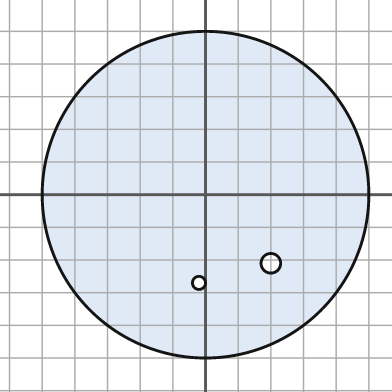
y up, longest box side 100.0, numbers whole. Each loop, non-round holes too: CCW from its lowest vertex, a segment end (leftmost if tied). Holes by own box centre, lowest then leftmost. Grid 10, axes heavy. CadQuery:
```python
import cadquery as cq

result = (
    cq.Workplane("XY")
    .moveTo(0.0, 0.0)
    .circle(50.0)
    .moveTo(-2.0, -27.0)
    .circle(2.0)
    .moveTo(20.0, -21.0)
    .circle(3.0)
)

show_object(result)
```